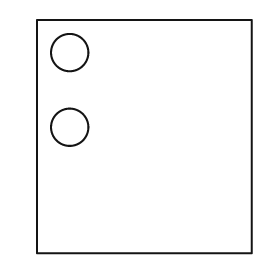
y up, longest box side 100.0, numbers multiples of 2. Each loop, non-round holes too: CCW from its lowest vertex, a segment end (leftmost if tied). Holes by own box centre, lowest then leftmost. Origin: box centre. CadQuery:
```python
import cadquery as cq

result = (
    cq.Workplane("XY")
    .moveTo(-46.0, -50.0)
    .lineTo(46.0, -50.0)
    .lineTo(46.0, 50.0)
    .lineTo(-46.0, 50.0)
    .close()
    .moveTo(-32.0, 4.0)
    .circle(8.0)
    .moveTo(-32.0, 36.0)
    .circle(8.0)
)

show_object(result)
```